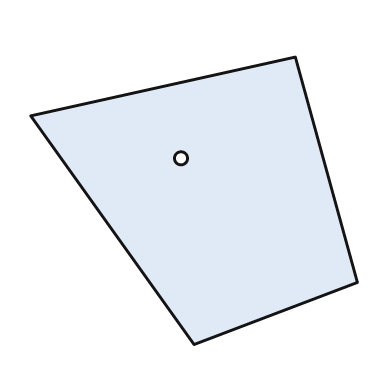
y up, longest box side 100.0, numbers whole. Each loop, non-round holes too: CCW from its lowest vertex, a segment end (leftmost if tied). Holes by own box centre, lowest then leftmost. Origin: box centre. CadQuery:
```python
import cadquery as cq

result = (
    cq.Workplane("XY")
    .moveTo(0.0, -44.0)
    .lineTo(50.0, -25.0)
    .lineTo(31.0, 44.0)
    .lineTo(-50.0, 26.0)
    .close()
    .moveTo(-4.0, 13.0)
    .circle(2.0)
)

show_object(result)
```